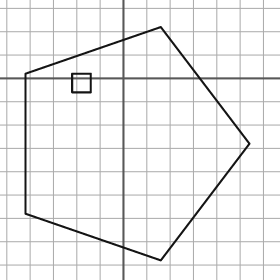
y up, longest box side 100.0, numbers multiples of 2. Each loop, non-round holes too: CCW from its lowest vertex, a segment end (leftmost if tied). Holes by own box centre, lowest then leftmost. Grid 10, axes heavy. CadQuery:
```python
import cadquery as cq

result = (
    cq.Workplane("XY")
    .moveTo(16.0, -78.0)
    .lineTo(54.0, -28.0)
    .lineTo(16.0, 22.0)
    .lineTo(-42.0, 2.0)
    .lineTo(-42.0, -58.0)
    .close()
    .moveTo(-22.0, -6.0)
    .lineTo(-14.0, -6.0)
    .lineTo(-14.0, 2.0)
    .lineTo(-22.0, 2.0)
    .close()
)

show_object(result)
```